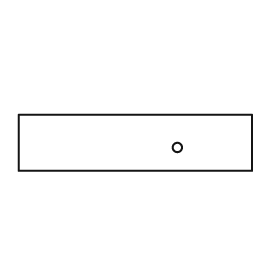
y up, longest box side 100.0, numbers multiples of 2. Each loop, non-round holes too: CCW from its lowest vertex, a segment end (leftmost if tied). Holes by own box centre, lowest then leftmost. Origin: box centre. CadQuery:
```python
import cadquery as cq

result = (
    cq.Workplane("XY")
    .moveTo(-50.0, -12.0)
    .lineTo(50.0, -12.0)
    .lineTo(50.0, 12.0)
    .lineTo(-50.0, 12.0)
    .close()
    .moveTo(18.0, -2.0)
    .circle(2.0)
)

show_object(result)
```